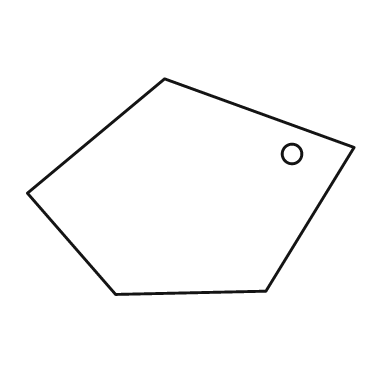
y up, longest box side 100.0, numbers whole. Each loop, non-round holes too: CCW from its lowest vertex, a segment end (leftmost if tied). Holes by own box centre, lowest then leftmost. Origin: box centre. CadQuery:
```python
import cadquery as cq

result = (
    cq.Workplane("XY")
    .moveTo(-23.0, -33.0)
    .lineTo(23.0, -32.0)
    .lineTo(50.0, 12.0)
    .lineTo(-8.0, 33.0)
    .lineTo(-50.0, -2.0)
    .close()
    .moveTo(31.0, 10.0)
    .circle(3.0)
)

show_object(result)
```